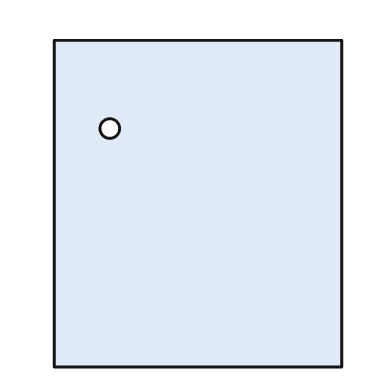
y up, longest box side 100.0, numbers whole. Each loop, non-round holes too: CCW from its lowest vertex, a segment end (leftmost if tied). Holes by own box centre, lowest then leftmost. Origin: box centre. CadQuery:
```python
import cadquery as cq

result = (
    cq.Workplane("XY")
    .moveTo(-44.0, -50.0)
    .lineTo(44.0, -50.0)
    .lineTo(44.0, 50.0)
    .lineTo(-44.0, 50.0)
    .close()
    .moveTo(-27.0, 23.0)
    .circle(3.0)
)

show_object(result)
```